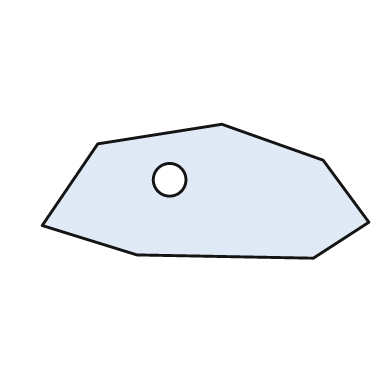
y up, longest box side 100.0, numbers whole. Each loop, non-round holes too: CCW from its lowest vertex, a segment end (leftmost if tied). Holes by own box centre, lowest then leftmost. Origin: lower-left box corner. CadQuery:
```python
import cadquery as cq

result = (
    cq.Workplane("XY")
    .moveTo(83.0, 0.0)
    .lineTo(100.0, 11.0)
    .lineTo(86.0, 30.0)
    .lineTo(55.0, 41.0)
    .lineTo(17.0, 35.0)
    .lineTo(0.0, 10.0)
    .lineTo(29.0, 1.0)
    .close()
    .moveTo(39.0, 24.0)
    .circle(5.0)
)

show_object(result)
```